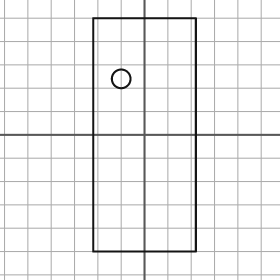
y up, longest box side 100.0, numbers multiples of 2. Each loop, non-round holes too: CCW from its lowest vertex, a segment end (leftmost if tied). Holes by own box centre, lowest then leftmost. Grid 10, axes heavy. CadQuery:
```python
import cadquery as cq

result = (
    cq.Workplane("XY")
    .moveTo(-22.0, -50.0)
    .lineTo(22.0, -50.0)
    .lineTo(22.0, 50.0)
    .lineTo(-22.0, 50.0)
    .close()
    .moveTo(-10.0, 24.0)
    .circle(4.0)
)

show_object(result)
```